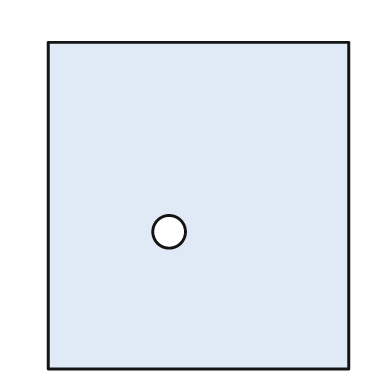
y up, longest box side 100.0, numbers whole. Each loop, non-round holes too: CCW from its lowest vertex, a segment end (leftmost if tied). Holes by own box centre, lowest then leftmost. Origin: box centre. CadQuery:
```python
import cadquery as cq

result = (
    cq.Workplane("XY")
    .moveTo(-46.0, -50.0)
    .lineTo(46.0, -50.0)
    .lineTo(46.0, 50.0)
    .lineTo(-46.0, 50.0)
    .close()
    .moveTo(-9.0, -8.0)
    .circle(5.0)
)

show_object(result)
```